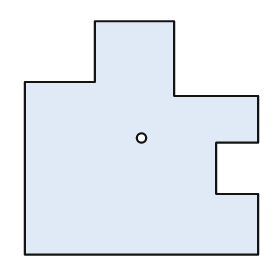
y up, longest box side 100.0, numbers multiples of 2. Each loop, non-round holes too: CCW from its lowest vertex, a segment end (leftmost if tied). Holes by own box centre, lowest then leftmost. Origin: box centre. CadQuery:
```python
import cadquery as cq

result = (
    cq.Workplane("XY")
    .moveTo(-50.0, -50.0)
    .lineTo(50.0, -50.0)
    .lineTo(50.0, -24.0)
    .lineTo(32.0, -24.0)
    .lineTo(32.0, -2.0)
    .lineTo(50.0, -2.0)
    .lineTo(50.0, 18.0)
    .lineTo(14.0, 18.0)
    .lineTo(14.0, 50.0)
    .lineTo(-20.0, 50.0)
    .lineTo(-20.0, 24.0)
    .lineTo(-50.0, 24.0)
    .close()
    .moveTo(0.0, 0.0)
    .circle(2.0)
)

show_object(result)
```